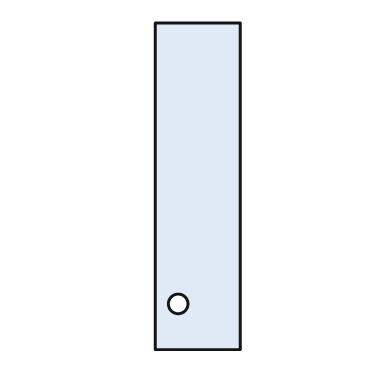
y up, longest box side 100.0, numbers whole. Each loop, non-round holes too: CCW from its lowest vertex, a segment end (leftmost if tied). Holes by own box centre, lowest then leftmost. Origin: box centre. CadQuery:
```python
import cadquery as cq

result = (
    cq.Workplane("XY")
    .moveTo(-13.0, -50.0)
    .lineTo(13.0, -50.0)
    .lineTo(13.0, 50.0)
    .lineTo(-13.0, 50.0)
    .close()
    .moveTo(-6.0, -36.0)
    .circle(3.0)
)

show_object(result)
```